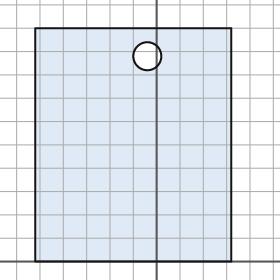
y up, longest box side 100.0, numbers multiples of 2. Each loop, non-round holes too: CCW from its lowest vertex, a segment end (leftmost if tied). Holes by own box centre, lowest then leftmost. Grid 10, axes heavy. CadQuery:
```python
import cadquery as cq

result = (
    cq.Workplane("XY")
    .moveTo(-52.0, 0.0)
    .lineTo(32.0, 0.0)
    .lineTo(32.0, 100.0)
    .lineTo(-52.0, 100.0)
    .close()
    .moveTo(-4.0, 88.0)
    .circle(6.0)
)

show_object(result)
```